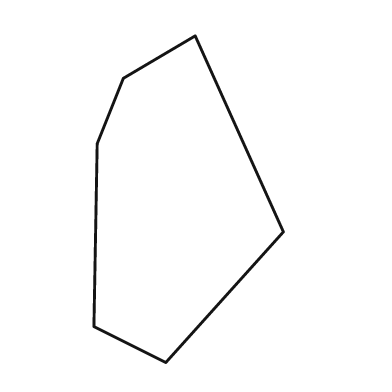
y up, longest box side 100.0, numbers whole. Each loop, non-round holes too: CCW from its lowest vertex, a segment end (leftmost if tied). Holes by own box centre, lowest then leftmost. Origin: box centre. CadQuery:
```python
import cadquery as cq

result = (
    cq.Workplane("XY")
    .moveTo(-7.0, -50.0)
    .lineTo(29.0, -10.0)
    .lineTo(2.0, 50.0)
    .lineTo(-20.0, 37.0)
    .lineTo(-28.0, 17.0)
    .lineTo(-29.0, -39.0)
    .close()
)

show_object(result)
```